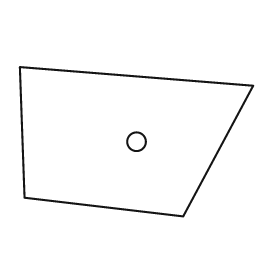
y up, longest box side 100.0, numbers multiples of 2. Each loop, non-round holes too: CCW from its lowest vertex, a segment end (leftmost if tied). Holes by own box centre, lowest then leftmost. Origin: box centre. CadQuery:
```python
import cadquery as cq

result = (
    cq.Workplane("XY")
    .moveTo(20.0, -32.0)
    .lineTo(50.0, 24.0)
    .lineTo(-50.0, 32.0)
    .lineTo(-48.0, -24.0)
    .close()
    .moveTo(0.0, 0.0)
    .circle(4.0)
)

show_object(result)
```